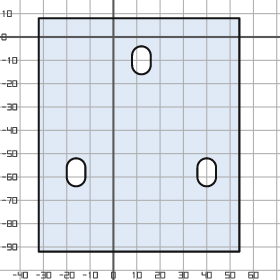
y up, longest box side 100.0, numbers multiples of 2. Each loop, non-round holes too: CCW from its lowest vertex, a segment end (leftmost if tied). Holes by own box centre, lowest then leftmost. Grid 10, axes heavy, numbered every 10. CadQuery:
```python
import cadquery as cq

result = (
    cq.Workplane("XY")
    .moveTo(-32.0, -92.0)
    .lineTo(54.0, -92.0)
    .lineTo(54.0, 8.0)
    .lineTo(-32.0, 8.0)
    .close()
    .moveTo(-20.0, -60.0)
    .threePointArc((-16.0, -64.0), (-12.0, -60.0))
    .lineTo(-12.0, -56.0)
    .threePointArc((-16.0, -52.0), (-20.0, -56.0))
    .close()
    .moveTo(36.0, -60.0)
    .threePointArc((40.0, -64.0), (44.0, -60.0))
    .lineTo(44.0, -56.0)
    .threePointArc((40.0, -52.0), (36.0, -56.0))
    .close()
    .moveTo(8.0, -12.0)
    .threePointArc((12.0, -16.0), (16.0, -12.0))
    .lineTo(16.0, -8.0)
    .threePointArc((12.0, -4.0), (8.0, -8.0))
    .close()
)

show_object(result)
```